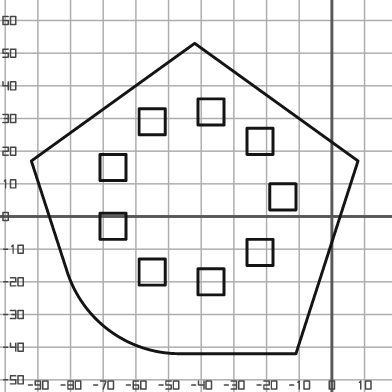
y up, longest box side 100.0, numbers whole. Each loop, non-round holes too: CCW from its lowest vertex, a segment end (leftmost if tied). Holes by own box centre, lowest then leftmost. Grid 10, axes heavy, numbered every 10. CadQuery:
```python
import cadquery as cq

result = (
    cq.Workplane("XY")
    .moveTo(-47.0, -42.0)
    .lineTo(-11.0, -42.0)
    .lineTo(8.0, 17.0)
    .lineTo(-42.0, 53.0)
    .lineTo(-92.0, 17.0)
    .lineTo(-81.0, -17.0)
    .threePointArc((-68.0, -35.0), (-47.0, -42.0))
    .close()
    .moveTo(-41.0, -24.0)
    .lineTo(-33.0, -24.0)
    .lineTo(-33.0, -16.0)
    .lineTo(-41.0, -16.0)
    .close()
    .moveTo(-59.0, -21.0)
    .lineTo(-51.0, -21.0)
    .lineTo(-51.0, -13.0)
    .lineTo(-59.0, -13.0)
    .close()
    .moveTo(-26.0, -15.0)
    .lineTo(-18.0, -15.0)
    .lineTo(-18.0, -7.0)
    .lineTo(-26.0, -7.0)
    .close()
    .moveTo(-71.0, -7.0)
    .lineTo(-63.0, -7.0)
    .lineTo(-63.0, 1.0)
    .lineTo(-71.0, 1.0)
    .close()
    .moveTo(-19.0, 2.0)
    .lineTo(-11.0, 2.0)
    .lineTo(-11.0, 10.0)
    .lineTo(-19.0, 10.0)
    .close()
    .moveTo(-71.0, 11.0)
    .lineTo(-63.0, 11.0)
    .lineTo(-63.0, 19.0)
    .lineTo(-71.0, 19.0)
    .close()
    .moveTo(-26.0, 19.0)
    .lineTo(-18.0, 19.0)
    .lineTo(-18.0, 27.0)
    .lineTo(-26.0, 27.0)
    .close()
    .moveTo(-59.0, 25.0)
    .lineTo(-51.0, 25.0)
    .lineTo(-51.0, 33.0)
    .lineTo(-59.0, 33.0)
    .close()
    .moveTo(-41.0, 28.0)
    .lineTo(-33.0, 28.0)
    .lineTo(-33.0, 36.0)
    .lineTo(-41.0, 36.0)
    .close()
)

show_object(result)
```